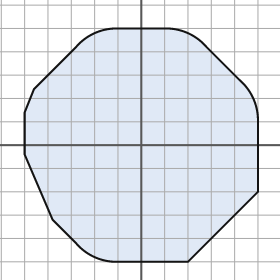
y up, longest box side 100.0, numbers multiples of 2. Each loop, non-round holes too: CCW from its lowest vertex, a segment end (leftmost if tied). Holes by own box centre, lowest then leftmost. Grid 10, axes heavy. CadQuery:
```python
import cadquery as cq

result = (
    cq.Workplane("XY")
    .moveTo(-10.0, -50.0)
    .lineTo(20.0, -50.0)
    .lineTo(50.0, -20.0)
    .lineTo(50.0, 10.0)
    .threePointArc((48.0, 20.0), (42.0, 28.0))
    .lineTo(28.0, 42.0)
    .threePointArc((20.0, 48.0), (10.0, 50.0))
    .lineTo(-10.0, 50.0)
    .threePointArc((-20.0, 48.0), (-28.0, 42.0))
    .lineTo(-46.0, 24.0)
    .lineTo(-50.0, 14.0)
    .lineTo(-50.0, -4.0)
    .lineTo(-38.0, -32.0)
    .lineTo(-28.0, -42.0)
    .threePointArc((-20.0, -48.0), (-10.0, -50.0))
    .close()
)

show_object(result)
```